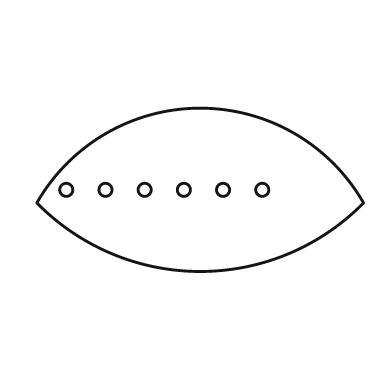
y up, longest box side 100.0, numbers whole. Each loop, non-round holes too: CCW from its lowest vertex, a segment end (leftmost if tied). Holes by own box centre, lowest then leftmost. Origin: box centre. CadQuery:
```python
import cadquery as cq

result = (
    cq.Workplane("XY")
    .moveTo(-50.0, -4.0)
    .threePointArc((0.0, -25.0), (50.0, -4.0))
    .threePointArc((0.0, 25.0), (-50.0, -4.0))
    .close()
    .moveTo(-41.0, 0.0)
    .circle(2.0)
    .moveTo(-29.0, 0.0)
    .circle(2.0)
    .moveTo(-17.0, 0.0)
    .circle(2.0)
    .moveTo(-5.0, 0.0)
    .circle(2.0)
    .moveTo(7.0, 0.0)
    .circle(2.0)
    .moveTo(19.0, 0.0)
    .circle(2.0)
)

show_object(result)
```